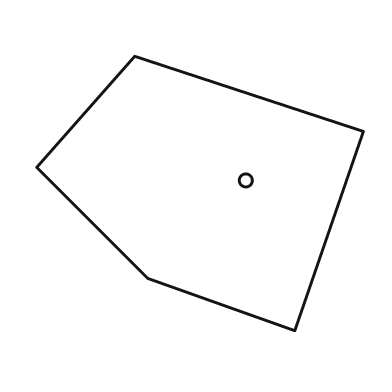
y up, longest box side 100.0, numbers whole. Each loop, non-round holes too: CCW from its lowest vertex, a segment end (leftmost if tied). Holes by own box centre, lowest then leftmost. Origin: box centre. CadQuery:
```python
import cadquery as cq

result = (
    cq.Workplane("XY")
    .moveTo(29.0, -42.0)
    .lineTo(50.0, 19.0)
    .lineTo(-20.0, 42.0)
    .lineTo(-50.0, 8.0)
    .lineTo(-16.0, -26.0)
    .close()
    .moveTo(14.0, 4.0)
    .circle(2.0)
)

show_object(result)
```